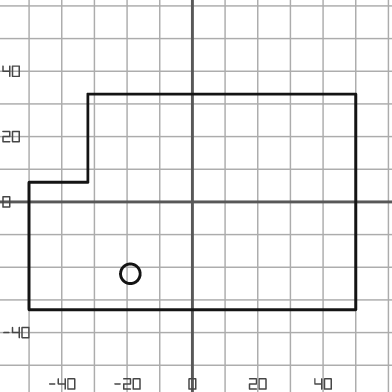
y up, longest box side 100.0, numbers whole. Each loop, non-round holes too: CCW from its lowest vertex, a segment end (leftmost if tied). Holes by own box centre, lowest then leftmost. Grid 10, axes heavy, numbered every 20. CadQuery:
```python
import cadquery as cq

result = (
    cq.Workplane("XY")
    .moveTo(-50.0, -33.0)
    .lineTo(50.0, -33.0)
    .lineTo(50.0, 33.0)
    .lineTo(-32.0, 33.0)
    .lineTo(-32.0, 6.0)
    .lineTo(-50.0, 6.0)
    .close()
    .moveTo(-19.0, -22.0)
    .circle(3.0)
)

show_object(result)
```